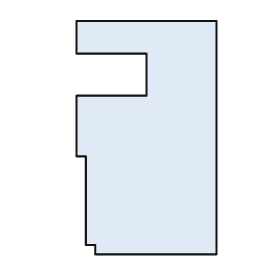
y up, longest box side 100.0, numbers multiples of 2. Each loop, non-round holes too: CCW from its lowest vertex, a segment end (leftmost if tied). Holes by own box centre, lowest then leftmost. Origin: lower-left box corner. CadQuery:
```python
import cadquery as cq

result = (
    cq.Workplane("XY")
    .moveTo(8.0, 0.0)
    .lineTo(60.0, 0.0)
    .lineTo(60.0, 100.0)
    .lineTo(0.0, 100.0)
    .lineTo(0.0, 86.0)
    .lineTo(30.0, 86.0)
    .lineTo(30.0, 68.0)
    .lineTo(0.0, 68.0)
    .lineTo(0.0, 42.0)
    .lineTo(4.0, 42.0)
    .lineTo(4.0, 4.0)
    .lineTo(8.0, 4.0)
    .close()
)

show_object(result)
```